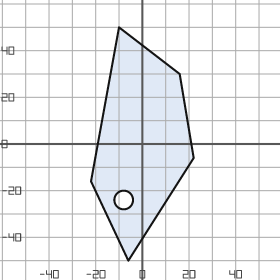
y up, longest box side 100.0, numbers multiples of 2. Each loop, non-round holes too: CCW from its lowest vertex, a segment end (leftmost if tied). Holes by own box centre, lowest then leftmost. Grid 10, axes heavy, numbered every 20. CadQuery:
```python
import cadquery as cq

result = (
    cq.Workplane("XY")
    .moveTo(-6.0, -50.0)
    .lineTo(22.0, -6.0)
    .lineTo(16.0, 30.0)
    .lineTo(-10.0, 50.0)
    .lineTo(-22.0, -16.0)
    .close()
    .moveTo(-8.0, -24.0)
    .circle(4.0)
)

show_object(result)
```